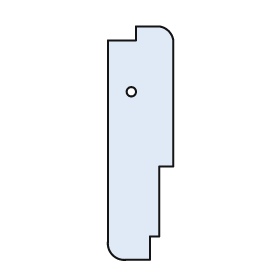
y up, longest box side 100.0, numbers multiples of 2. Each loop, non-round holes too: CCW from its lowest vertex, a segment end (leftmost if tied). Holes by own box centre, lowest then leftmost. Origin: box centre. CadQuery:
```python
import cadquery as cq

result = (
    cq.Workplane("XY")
    .moveTo(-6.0, -50.0)
    .lineTo(4.0, -50.0)
    .lineTo(4.0, -40.0)
    .lineTo(8.0, -40.0)
    .lineTo(8.0, -10.0)
    .lineTo(14.0, -10.0)
    .lineTo(14.0, 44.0)
    .threePointArc((12.0, 48.0), (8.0, 50.0))
    .lineTo(-2.0, 50.0)
    .lineTo(-2.0, 44.0)
    .lineTo(-14.0, 44.0)
    .lineTo(-14.0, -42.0)
    .threePointArc((-12.0, -48.0), (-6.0, -50.0))
    .close()
    .moveTo(-4.0, 22.0)
    .circle(2.0)
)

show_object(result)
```